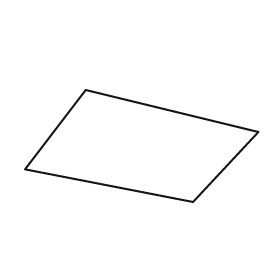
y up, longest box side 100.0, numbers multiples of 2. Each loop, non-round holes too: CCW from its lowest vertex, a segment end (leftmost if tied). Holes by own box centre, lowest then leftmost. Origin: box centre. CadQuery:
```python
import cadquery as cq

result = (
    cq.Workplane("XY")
    .moveTo(22.0, -24.0)
    .lineTo(50.0, 6.0)
    .lineTo(-24.0, 24.0)
    .lineTo(-50.0, -10.0)
    .close()
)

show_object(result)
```